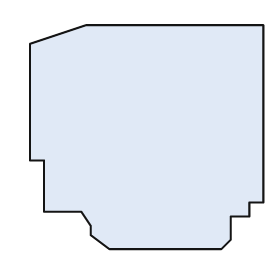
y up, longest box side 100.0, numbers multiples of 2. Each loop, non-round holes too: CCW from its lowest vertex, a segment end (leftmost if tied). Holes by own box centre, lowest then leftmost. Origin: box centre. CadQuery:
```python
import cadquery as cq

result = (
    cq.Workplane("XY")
    .moveTo(-16.0, -48.0)
    .lineTo(32.0, -48.0)
    .lineTo(36.0, -44.0)
    .lineTo(36.0, -34.0)
    .lineTo(44.0, -34.0)
    .lineTo(44.0, -28.0)
    .lineTo(50.0, -28.0)
    .lineTo(50.0, 48.0)
    .lineTo(-26.0, 48.0)
    .lineTo(-50.0, 40.0)
    .lineTo(-50.0, -10.0)
    .lineTo(-44.0, -10.0)
    .lineTo(-44.0, -32.0)
    .lineTo(-28.0, -32.0)
    .lineTo(-24.0, -38.0)
    .lineTo(-24.0, -42.0)
    .close()
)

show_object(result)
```